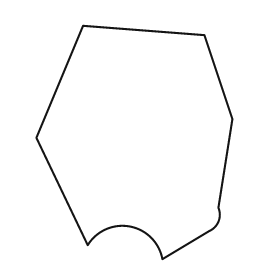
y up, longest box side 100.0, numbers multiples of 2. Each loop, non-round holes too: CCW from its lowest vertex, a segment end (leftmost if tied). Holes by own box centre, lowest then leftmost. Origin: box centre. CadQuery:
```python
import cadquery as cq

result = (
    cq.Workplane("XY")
    .moveTo(12.0, -50.0)
    .lineTo(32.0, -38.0)
    .threePointArc((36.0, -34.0), (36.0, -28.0))
    .lineTo(42.0, 10.0)
    .lineTo(30.0, 46.0)
    .lineTo(-22.0, 50.0)
    .lineTo(-42.0, 2.0)
    .lineTo(-20.0, -44.0)
    .threePointArc((-2.0, -36.0), (12.0, -50.0))
    .close()
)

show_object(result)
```